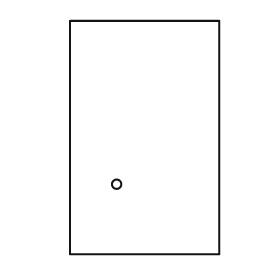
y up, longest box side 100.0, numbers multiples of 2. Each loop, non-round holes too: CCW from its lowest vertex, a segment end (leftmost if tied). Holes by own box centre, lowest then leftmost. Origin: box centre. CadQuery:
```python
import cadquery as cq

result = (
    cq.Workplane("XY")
    .moveTo(-32.0, -50.0)
    .lineTo(32.0, -50.0)
    .lineTo(32.0, 50.0)
    .lineTo(-32.0, 50.0)
    .close()
    .moveTo(-12.0, -20.0)
    .circle(2.0)
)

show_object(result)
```